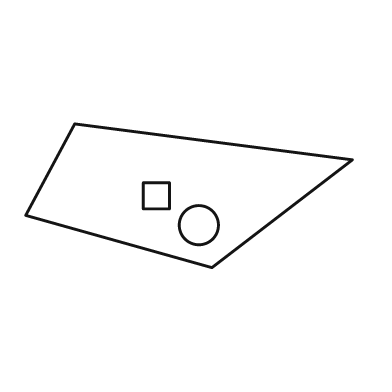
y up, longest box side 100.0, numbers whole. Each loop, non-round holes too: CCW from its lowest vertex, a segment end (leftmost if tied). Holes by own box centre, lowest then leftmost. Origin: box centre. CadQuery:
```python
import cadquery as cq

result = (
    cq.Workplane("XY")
    .moveTo(7.0, -22.0)
    .lineTo(50.0, 11.0)
    .lineTo(-35.0, 22.0)
    .lineTo(-50.0, -6.0)
    .close()
    .moveTo(3.0, -9.0)
    .circle(6.0)
    .moveTo(-14.0, -4.0)
    .lineTo(-6.0, -4.0)
    .lineTo(-6.0, 4.0)
    .lineTo(-14.0, 4.0)
    .close()
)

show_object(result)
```